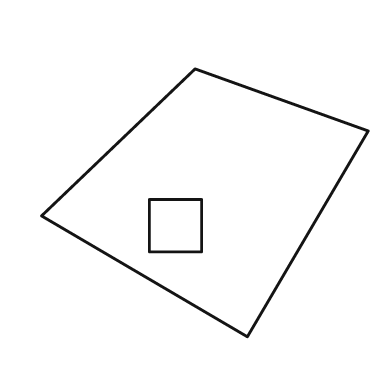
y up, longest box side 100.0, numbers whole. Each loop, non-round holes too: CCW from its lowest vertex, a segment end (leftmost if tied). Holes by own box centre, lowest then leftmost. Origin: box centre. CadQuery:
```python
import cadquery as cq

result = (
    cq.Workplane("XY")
    .moveTo(13.0, -41.0)
    .lineTo(50.0, 22.0)
    .lineTo(-3.0, 41.0)
    .lineTo(-50.0, -4.0)
    .close()
    .moveTo(-17.0, -15.0)
    .lineTo(-1.0, -15.0)
    .lineTo(-1.0, 1.0)
    .lineTo(-17.0, 1.0)
    .close()
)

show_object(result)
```